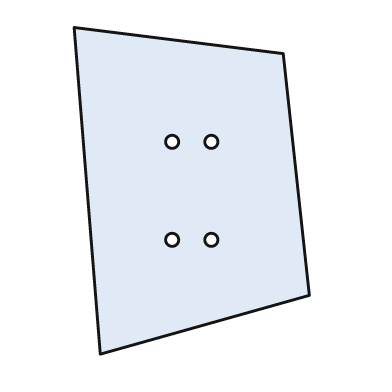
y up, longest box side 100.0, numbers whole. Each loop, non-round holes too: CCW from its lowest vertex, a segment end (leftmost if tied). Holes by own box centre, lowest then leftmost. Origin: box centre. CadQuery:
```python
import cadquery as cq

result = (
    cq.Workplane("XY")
    .moveTo(-28.0, -50.0)
    .lineTo(36.0, -32.0)
    .lineTo(28.0, 42.0)
    .lineTo(-36.0, 50.0)
    .close()
    .moveTo(-6.0, -15.0)
    .circle(2.0)
    .moveTo(6.0, -15.0)
    .circle(2.0)
    .moveTo(-6.0, 15.0)
    .circle(2.0)
    .moveTo(6.0, 15.0)
    .circle(2.0)
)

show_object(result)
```